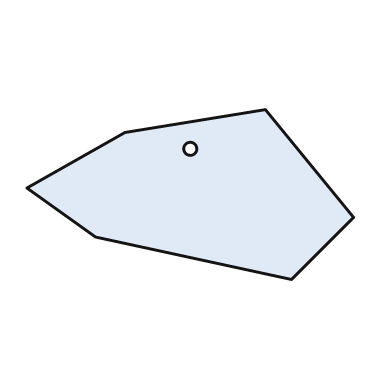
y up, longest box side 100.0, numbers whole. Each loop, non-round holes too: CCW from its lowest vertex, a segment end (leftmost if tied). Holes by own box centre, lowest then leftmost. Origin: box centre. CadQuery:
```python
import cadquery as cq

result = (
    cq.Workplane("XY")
    .moveTo(31.0, -26.0)
    .lineTo(50.0, -7.0)
    .lineTo(23.0, 26.0)
    .lineTo(-20.0, 19.0)
    .lineTo(-50.0, 2.0)
    .lineTo(-29.0, -13.0)
    .close()
    .moveTo(0.0, 14.0)
    .circle(2.0)
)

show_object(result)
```